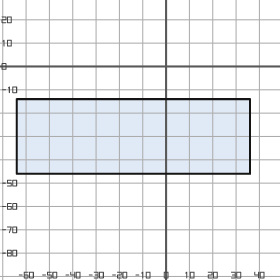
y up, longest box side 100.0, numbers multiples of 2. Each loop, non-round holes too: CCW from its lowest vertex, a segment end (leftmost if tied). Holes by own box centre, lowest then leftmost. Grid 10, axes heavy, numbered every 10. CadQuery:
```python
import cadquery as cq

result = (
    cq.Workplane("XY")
    .moveTo(-64.0, -46.0)
    .lineTo(36.0, -46.0)
    .lineTo(36.0, -14.0)
    .lineTo(-64.0, -14.0)
    .close()
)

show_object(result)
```